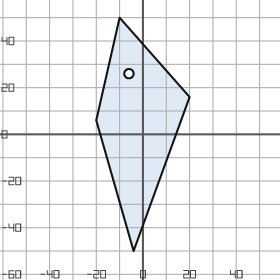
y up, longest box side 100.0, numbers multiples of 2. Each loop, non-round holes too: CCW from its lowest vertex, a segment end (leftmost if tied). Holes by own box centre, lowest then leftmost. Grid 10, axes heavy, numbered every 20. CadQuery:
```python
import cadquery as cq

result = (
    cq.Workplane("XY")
    .moveTo(-4.0, -50.0)
    .lineTo(20.0, 16.0)
    .lineTo(-10.0, 50.0)
    .lineTo(-20.0, 6.0)
    .close()
    .moveTo(-6.0, 26.0)
    .circle(2.0)
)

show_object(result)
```